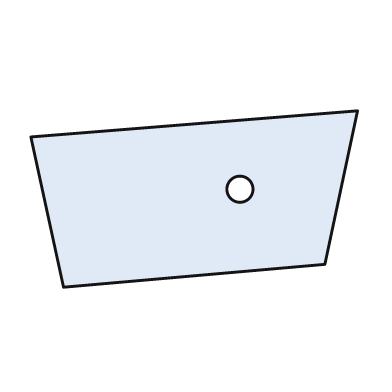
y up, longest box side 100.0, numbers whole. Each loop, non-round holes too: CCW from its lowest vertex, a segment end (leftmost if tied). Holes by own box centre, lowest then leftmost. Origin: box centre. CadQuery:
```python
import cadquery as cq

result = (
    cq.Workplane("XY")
    .moveTo(-40.0, -27.0)
    .lineTo(40.0, -20.0)
    .lineTo(50.0, 27.0)
    .lineTo(-50.0, 19.0)
    .close()
    .moveTo(14.0, 3.0)
    .circle(4.0)
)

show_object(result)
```